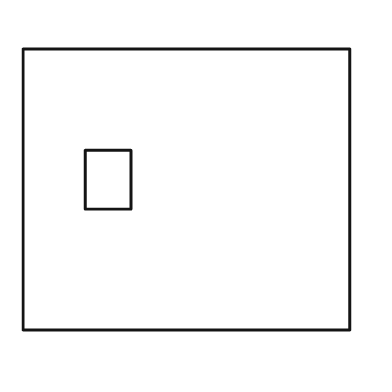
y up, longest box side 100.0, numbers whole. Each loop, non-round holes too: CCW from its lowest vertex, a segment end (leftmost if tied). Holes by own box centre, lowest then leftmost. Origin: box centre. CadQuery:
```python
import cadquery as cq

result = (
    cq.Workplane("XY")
    .moveTo(-50.0, -43.0)
    .lineTo(50.0, -43.0)
    .lineTo(50.0, 43.0)
    .lineTo(-50.0, 43.0)
    .close()
    .moveTo(-31.0, -6.0)
    .lineTo(-17.0, -6.0)
    .lineTo(-17.0, 12.0)
    .lineTo(-31.0, 12.0)
    .close()
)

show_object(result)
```